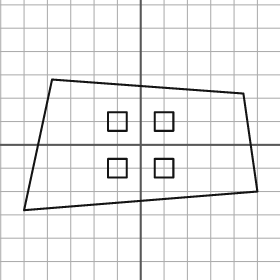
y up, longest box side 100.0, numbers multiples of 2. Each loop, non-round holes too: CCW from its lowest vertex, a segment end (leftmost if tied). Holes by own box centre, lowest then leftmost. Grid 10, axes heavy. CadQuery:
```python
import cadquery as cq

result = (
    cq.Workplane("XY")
    .moveTo(-50.0, -28.0)
    .lineTo(50.0, -20.0)
    .lineTo(44.0, 22.0)
    .lineTo(-38.0, 28.0)
    .close()
    .moveTo(-14.0, -14.0)
    .lineTo(-6.0, -14.0)
    .lineTo(-6.0, -6.0)
    .lineTo(-14.0, -6.0)
    .close()
    .moveTo(6.0, -14.0)
    .lineTo(14.0, -14.0)
    .lineTo(14.0, -6.0)
    .lineTo(6.0, -6.0)
    .close()
    .moveTo(-14.0, 6.0)
    .lineTo(-6.0, 6.0)
    .lineTo(-6.0, 14.0)
    .lineTo(-14.0, 14.0)
    .close()
    .moveTo(6.0, 6.0)
    .lineTo(14.0, 6.0)
    .lineTo(14.0, 14.0)
    .lineTo(6.0, 14.0)
    .close()
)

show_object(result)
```